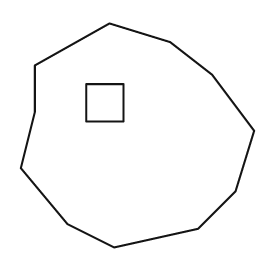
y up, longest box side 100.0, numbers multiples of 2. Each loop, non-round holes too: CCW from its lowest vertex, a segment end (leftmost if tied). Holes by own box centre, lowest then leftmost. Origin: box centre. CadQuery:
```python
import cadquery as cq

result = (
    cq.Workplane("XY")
    .moveTo(-10.0, -48.0)
    .lineTo(26.0, -40.0)
    .lineTo(42.0, -24.0)
    .lineTo(50.0, 2.0)
    .lineTo(32.0, 26.0)
    .lineTo(14.0, 40.0)
    .lineTo(-12.0, 48.0)
    .lineTo(-44.0, 30.0)
    .lineTo(-44.0, 10.0)
    .lineTo(-50.0, -14.0)
    .lineTo(-30.0, -38.0)
    .close()
    .moveTo(-22.0, 6.0)
    .lineTo(-6.0, 6.0)
    .lineTo(-6.0, 22.0)
    .lineTo(-22.0, 22.0)
    .close()
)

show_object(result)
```